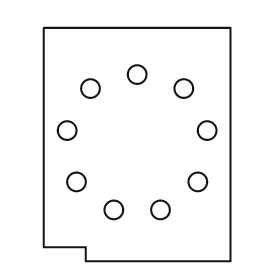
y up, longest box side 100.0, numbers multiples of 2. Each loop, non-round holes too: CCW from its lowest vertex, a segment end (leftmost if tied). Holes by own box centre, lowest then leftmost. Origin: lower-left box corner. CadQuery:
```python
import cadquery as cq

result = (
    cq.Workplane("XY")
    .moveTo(18.0, 0.0)
    .lineTo(80.0, 0.0)
    .lineTo(80.0, 100.0)
    .lineTo(0.0, 100.0)
    .lineTo(0.0, 6.0)
    .lineTo(18.0, 6.0)
    .close()
    .moveTo(30.0, 22.0)
    .circle(4.0)
    .moveTo(50.0, 22.0)
    .circle(4.0)
    .moveTo(14.0, 34.0)
    .circle(4.0)
    .moveTo(66.0, 34.0)
    .circle(4.0)
    .moveTo(10.0, 56.0)
    .circle(4.0)
    .moveTo(70.0, 56.0)
    .circle(4.0)
    .moveTo(20.0, 74.0)
    .circle(4.0)
    .moveTo(60.0, 74.0)
    .circle(4.0)
    .moveTo(40.0, 80.0)
    .circle(4.0)
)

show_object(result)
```